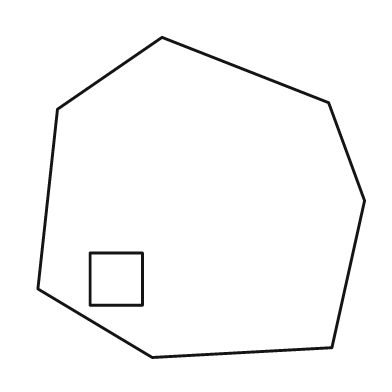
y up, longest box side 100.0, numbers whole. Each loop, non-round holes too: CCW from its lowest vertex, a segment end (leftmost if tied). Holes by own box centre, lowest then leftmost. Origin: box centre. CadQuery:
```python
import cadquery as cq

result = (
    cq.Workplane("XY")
    .moveTo(-15.0, -49.0)
    .lineTo(40.0, -46.0)
    .lineTo(50.0, -1.0)
    .lineTo(39.0, 29.0)
    .lineTo(-12.0, 49.0)
    .lineTo(-44.0, 27.0)
    .lineTo(-50.0, -28.0)
    .close()
    .moveTo(-34.0, -33.0)
    .lineTo(-18.0, -33.0)
    .lineTo(-18.0, -17.0)
    .lineTo(-34.0, -17.0)
    .close()
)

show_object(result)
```